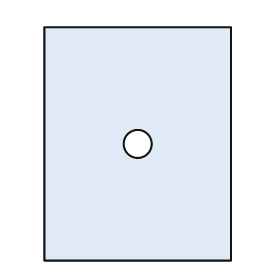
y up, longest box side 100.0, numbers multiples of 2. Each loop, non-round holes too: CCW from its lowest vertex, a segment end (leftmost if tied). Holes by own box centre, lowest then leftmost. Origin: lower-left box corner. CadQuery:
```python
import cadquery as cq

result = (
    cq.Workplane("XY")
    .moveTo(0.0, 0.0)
    .lineTo(80.0, 0.0)
    .lineTo(80.0, 100.0)
    .lineTo(0.0, 100.0)
    .close()
    .moveTo(40.0, 50.0)
    .circle(6.0)
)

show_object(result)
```